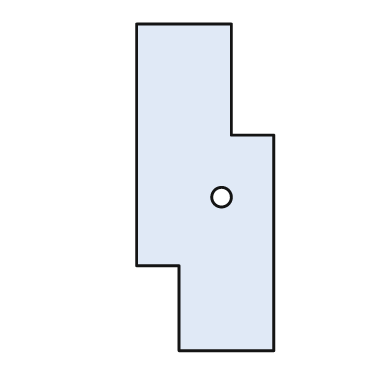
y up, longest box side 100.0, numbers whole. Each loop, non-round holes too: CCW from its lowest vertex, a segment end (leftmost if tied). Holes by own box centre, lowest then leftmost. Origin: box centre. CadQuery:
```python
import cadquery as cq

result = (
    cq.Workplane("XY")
    .moveTo(-8.0, -50.0)
    .lineTo(21.0, -50.0)
    .lineTo(21.0, 16.0)
    .lineTo(8.0, 16.0)
    .lineTo(8.0, 50.0)
    .lineTo(-21.0, 50.0)
    .lineTo(-21.0, -24.0)
    .lineTo(-8.0, -24.0)
    .close()
    .moveTo(5.0, -3.0)
    .circle(3.0)
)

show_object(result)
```